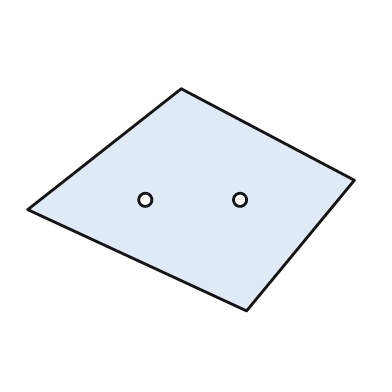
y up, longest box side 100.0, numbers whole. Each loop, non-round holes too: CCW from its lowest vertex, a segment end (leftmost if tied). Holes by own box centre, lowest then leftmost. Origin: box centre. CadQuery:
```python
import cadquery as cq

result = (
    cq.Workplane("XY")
    .moveTo(17.0, -34.0)
    .lineTo(50.0, 6.0)
    .lineTo(-3.0, 34.0)
    .lineTo(-50.0, -3.0)
    .close()
    .moveTo(-14.0, 0.0)
    .circle(2.0)
    .moveTo(15.0, 0.0)
    .circle(2.0)
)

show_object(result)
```